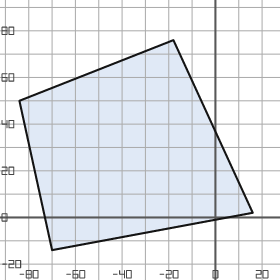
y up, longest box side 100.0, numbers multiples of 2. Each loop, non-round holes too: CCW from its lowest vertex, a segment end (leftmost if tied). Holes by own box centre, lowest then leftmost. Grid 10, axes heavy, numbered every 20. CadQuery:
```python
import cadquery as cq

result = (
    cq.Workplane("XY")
    .moveTo(-70.0, -14.0)
    .lineTo(16.0, 2.0)
    .lineTo(-18.0, 76.0)
    .lineTo(-84.0, 50.0)
    .close()
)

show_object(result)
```